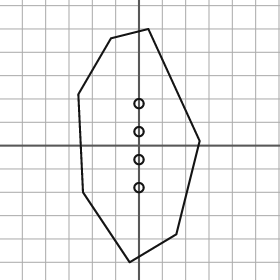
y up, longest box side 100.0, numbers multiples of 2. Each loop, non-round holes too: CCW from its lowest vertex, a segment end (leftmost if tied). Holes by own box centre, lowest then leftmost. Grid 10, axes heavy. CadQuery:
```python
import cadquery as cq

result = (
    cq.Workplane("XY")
    .moveTo(-4.0, -50.0)
    .lineTo(16.0, -38.0)
    .lineTo(26.0, 2.0)
    .lineTo(4.0, 50.0)
    .lineTo(-12.0, 46.0)
    .lineTo(-26.0, 22.0)
    .lineTo(-24.0, -20.0)
    .close()
    .moveTo(0.0, -18.0)
    .circle(2.0)
    .moveTo(0.0, -6.0)
    .circle(2.0)
    .moveTo(0.0, 6.0)
    .circle(2.0)
    .moveTo(0.0, 18.0)
    .circle(2.0)
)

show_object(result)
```